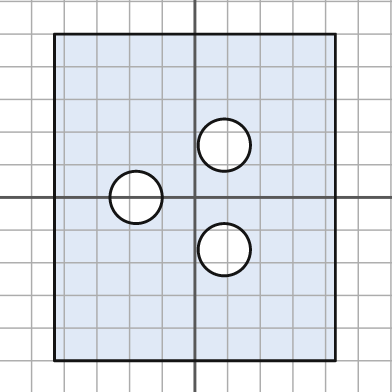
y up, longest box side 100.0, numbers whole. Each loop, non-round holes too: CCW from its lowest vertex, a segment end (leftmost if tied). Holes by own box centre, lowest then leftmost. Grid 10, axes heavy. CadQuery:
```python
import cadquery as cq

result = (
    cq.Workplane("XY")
    .moveTo(-43.0, -50.0)
    .lineTo(43.0, -50.0)
    .lineTo(43.0, 50.0)
    .lineTo(-43.0, 50.0)
    .close()
    .moveTo(9.0, -16.0)
    .circle(8.0)
    .moveTo(-18.0, 0.0)
    .circle(8.0)
    .moveTo(9.0, 16.0)
    .circle(8.0)
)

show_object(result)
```